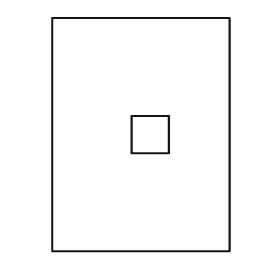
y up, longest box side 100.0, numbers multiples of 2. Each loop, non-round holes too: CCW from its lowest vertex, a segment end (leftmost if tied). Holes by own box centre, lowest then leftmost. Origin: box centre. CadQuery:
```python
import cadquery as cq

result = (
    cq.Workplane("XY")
    .moveTo(-38.0, -50.0)
    .lineTo(38.0, -50.0)
    .lineTo(38.0, 50.0)
    .lineTo(-38.0, 50.0)
    .close()
    .moveTo(-4.0, -8.0)
    .lineTo(12.0, -8.0)
    .lineTo(12.0, 8.0)
    .lineTo(-4.0, 8.0)
    .close()
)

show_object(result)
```